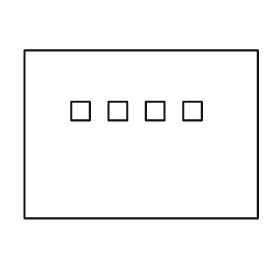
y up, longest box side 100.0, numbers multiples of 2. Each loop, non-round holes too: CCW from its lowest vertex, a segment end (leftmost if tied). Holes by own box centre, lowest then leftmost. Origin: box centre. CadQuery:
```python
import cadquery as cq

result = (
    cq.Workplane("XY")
    .moveTo(-50.0, -36.0)
    .lineTo(50.0, -36.0)
    .lineTo(50.0, 36.0)
    .lineTo(-50.0, 36.0)
    .close()
    .moveTo(-30.0, 6.0)
    .lineTo(-22.0, 6.0)
    .lineTo(-22.0, 14.0)
    .lineTo(-30.0, 14.0)
    .close()
    .moveTo(-14.0, 6.0)
    .lineTo(-6.0, 6.0)
    .lineTo(-6.0, 14.0)
    .lineTo(-14.0, 14.0)
    .close()
    .moveTo(2.0, 6.0)
    .lineTo(10.0, 6.0)
    .lineTo(10.0, 14.0)
    .lineTo(2.0, 14.0)
    .close()
    .moveTo(18.0, 6.0)
    .lineTo(26.0, 6.0)
    .lineTo(26.0, 14.0)
    .lineTo(18.0, 14.0)
    .close()
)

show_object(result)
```